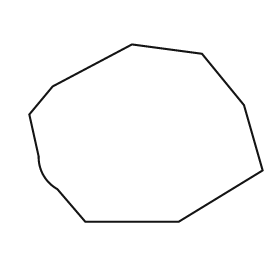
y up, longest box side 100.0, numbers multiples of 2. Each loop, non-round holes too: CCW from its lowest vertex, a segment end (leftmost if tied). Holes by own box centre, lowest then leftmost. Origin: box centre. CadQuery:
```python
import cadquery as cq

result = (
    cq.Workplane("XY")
    .moveTo(-26.0, -38.0)
    .lineTo(14.0, -38.0)
    .lineTo(50.0, -16.0)
    .lineTo(42.0, 12.0)
    .lineTo(24.0, 34.0)
    .lineTo(-6.0, 38.0)
    .lineTo(-40.0, 20.0)
    .lineTo(-50.0, 8.0)
    .lineTo(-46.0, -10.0)
    .threePointArc((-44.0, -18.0), (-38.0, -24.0))
    .close()
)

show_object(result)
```